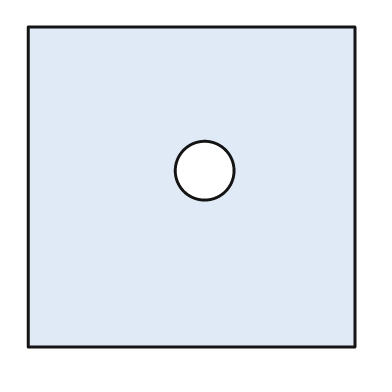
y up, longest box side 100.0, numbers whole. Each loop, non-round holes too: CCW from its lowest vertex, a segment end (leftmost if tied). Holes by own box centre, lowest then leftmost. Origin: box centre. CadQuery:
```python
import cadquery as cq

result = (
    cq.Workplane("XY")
    .moveTo(-50.0, -49.0)
    .lineTo(50.0, -49.0)
    .lineTo(50.0, 49.0)
    .lineTo(-50.0, 49.0)
    .close()
    .moveTo(4.0, 5.0)
    .circle(9.0)
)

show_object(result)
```